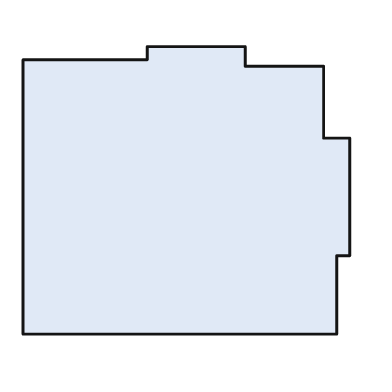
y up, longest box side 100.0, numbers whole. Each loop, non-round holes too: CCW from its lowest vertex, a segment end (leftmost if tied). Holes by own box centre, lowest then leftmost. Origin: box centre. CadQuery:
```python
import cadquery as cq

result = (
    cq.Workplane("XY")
    .moveTo(-50.0, -44.0)
    .lineTo(46.0, -44.0)
    .lineTo(46.0, -20.0)
    .lineTo(50.0, -20.0)
    .lineTo(50.0, 16.0)
    .lineTo(42.0, 16.0)
    .lineTo(42.0, 38.0)
    .lineTo(18.0, 38.0)
    .lineTo(18.0, 44.0)
    .lineTo(-12.0, 44.0)
    .lineTo(-12.0, 40.0)
    .lineTo(-50.0, 40.0)
    .close()
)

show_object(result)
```